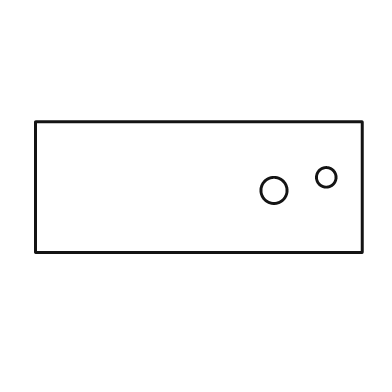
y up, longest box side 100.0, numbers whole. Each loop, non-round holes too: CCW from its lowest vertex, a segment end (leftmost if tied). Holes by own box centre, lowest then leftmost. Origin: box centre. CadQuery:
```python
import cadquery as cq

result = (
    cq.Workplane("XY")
    .moveTo(-50.0, -20.0)
    .lineTo(50.0, -20.0)
    .lineTo(50.0, 20.0)
    .lineTo(-50.0, 20.0)
    .close()
    .moveTo(23.0, -1.0)
    .circle(4.0)
    .moveTo(39.0, 3.0)
    .circle(3.0)
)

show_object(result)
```